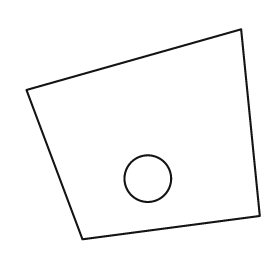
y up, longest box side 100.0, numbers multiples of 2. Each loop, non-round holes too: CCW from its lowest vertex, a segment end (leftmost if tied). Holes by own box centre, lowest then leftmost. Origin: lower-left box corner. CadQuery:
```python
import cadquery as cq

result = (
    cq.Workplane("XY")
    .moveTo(24.0, 0.0)
    .lineTo(100.0, 10.0)
    .lineTo(92.0, 90.0)
    .lineTo(0.0, 64.0)
    .close()
    .moveTo(52.0, 26.0)
    .circle(10.0)
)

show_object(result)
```